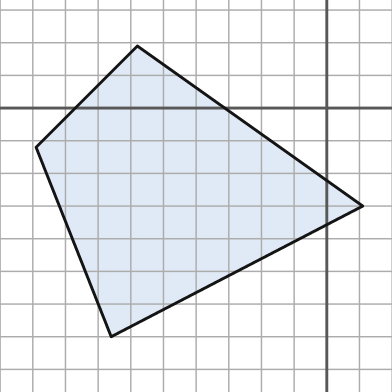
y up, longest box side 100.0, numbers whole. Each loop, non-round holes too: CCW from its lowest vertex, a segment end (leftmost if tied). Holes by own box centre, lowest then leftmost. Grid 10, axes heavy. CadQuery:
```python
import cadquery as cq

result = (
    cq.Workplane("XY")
    .moveTo(-66.0, -70.0)
    .lineTo(11.0, -30.0)
    .lineTo(-58.0, 19.0)
    .lineTo(-89.0, -12.0)
    .close()
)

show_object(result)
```